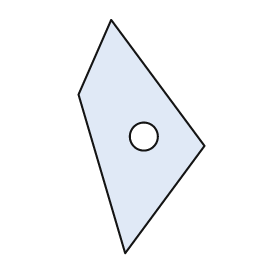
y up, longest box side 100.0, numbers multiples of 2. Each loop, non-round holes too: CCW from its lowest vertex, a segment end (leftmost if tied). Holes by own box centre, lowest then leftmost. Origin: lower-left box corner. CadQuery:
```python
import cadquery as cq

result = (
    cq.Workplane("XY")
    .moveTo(20.0, 0.0)
    .lineTo(54.0, 46.0)
    .lineTo(14.0, 100.0)
    .lineTo(0.0, 68.0)
    .close()
    .moveTo(28.0, 50.0)
    .circle(6.0)
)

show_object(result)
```